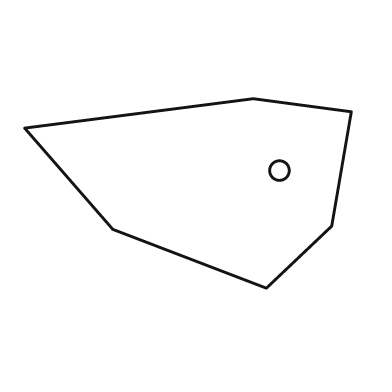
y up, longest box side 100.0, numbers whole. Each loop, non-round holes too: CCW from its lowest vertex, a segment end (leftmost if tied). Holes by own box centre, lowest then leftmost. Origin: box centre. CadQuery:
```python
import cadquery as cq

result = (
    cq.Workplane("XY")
    .moveTo(24.0, -29.0)
    .lineTo(44.0, -10.0)
    .lineTo(50.0, 25.0)
    .lineTo(20.0, 29.0)
    .lineTo(-50.0, 20.0)
    .lineTo(-23.0, -11.0)
    .close()
    .moveTo(28.0, 7.0)
    .circle(3.0)
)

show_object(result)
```